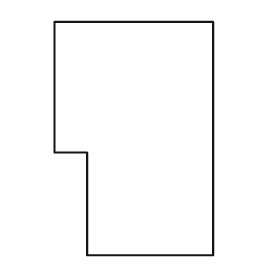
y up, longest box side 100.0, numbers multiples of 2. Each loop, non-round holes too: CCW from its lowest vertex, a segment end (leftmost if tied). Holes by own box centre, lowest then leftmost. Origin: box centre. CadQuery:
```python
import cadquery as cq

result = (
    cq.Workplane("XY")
    .moveTo(-20.0, -50.0)
    .lineTo(34.0, -50.0)
    .lineTo(34.0, 50.0)
    .lineTo(-34.0, 50.0)
    .lineTo(-34.0, -6.0)
    .lineTo(-20.0, -6.0)
    .close()
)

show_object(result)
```